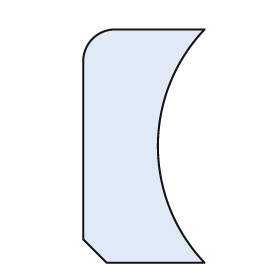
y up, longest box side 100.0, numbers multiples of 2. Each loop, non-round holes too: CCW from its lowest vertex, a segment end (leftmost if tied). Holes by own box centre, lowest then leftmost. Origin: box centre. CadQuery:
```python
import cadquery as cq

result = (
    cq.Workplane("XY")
    .moveTo(-16.0, -50.0)
    .lineTo(26.0, -50.0)
    .threePointArc((6.0, 0.0), (26.0, 50.0))
    .lineTo(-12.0, 50.0)
    .threePointArc((-22.0, 46.0), (-26.0, 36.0))
    .lineTo(-26.0, -40.0)
    .close()
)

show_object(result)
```